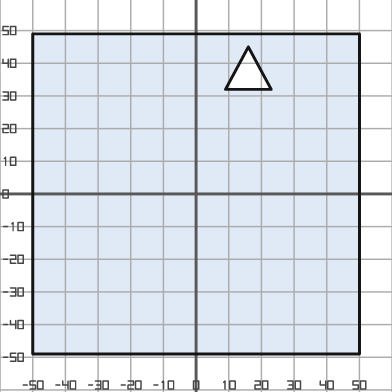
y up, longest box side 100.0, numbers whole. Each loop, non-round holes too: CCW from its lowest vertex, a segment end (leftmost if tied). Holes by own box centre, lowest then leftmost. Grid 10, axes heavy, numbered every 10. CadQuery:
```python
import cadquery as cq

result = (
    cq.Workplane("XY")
    .moveTo(-50.0, -49.0)
    .lineTo(50.0, -49.0)
    .lineTo(50.0, 49.0)
    .lineTo(-50.0, 49.0)
    .close()
    .moveTo(9.0, 32.0)
    .lineTo(23.0, 32.0)
    .lineTo(16.0, 45.0)
    .close()
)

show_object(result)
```